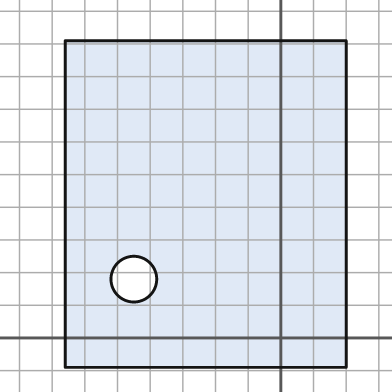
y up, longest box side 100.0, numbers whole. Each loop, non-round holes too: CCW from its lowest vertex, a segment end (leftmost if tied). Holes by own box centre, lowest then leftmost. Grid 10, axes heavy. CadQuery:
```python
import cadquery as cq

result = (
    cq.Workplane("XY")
    .moveTo(-66.0, -9.0)
    .lineTo(20.0, -9.0)
    .lineTo(20.0, 91.0)
    .lineTo(-66.0, 91.0)
    .close()
    .moveTo(-45.0, 18.0)
    .circle(7.0)
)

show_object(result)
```